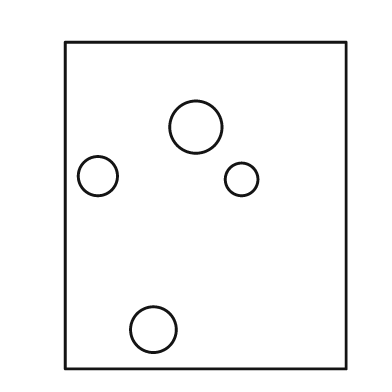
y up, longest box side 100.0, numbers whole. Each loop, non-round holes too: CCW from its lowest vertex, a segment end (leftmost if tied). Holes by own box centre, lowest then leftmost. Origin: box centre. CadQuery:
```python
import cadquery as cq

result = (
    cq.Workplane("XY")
    .moveTo(-43.0, -50.0)
    .lineTo(43.0, -50.0)
    .lineTo(43.0, 50.0)
    .lineTo(-43.0, 50.0)
    .close()
    .moveTo(-16.0, -38.0)
    .circle(7.0)
    .moveTo(11.0, 8.0)
    .circle(5.0)
    .moveTo(-33.0, 9.0)
    .circle(6.0)
    .moveTo(-3.0, 24.0)
    .circle(8.0)
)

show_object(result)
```